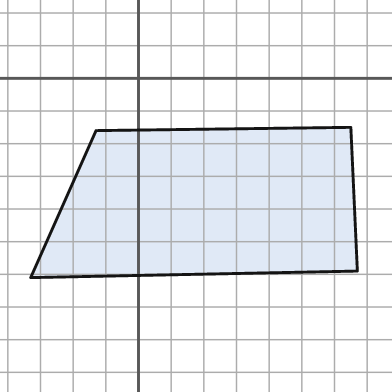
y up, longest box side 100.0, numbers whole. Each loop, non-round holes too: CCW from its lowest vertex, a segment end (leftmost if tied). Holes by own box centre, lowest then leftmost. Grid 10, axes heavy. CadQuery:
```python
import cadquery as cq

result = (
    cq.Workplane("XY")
    .moveTo(-33.0, -61.0)
    .lineTo(67.0, -59.0)
    .lineTo(65.0, -15.0)
    .lineTo(-13.0, -16.0)
    .close()
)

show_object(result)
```